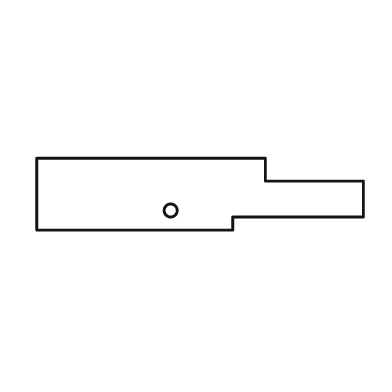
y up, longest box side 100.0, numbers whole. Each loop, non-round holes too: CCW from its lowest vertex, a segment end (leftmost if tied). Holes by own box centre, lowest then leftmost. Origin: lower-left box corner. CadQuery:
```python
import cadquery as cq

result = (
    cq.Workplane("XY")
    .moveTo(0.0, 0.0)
    .lineTo(60.0, 0.0)
    .lineTo(60.0, 4.0)
    .lineTo(100.0, 4.0)
    .lineTo(100.0, 15.0)
    .lineTo(70.0, 15.0)
    .lineTo(70.0, 22.0)
    .lineTo(0.0, 22.0)
    .close()
    .moveTo(41.0, 6.0)
    .circle(2.0)
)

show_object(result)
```